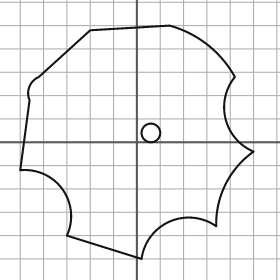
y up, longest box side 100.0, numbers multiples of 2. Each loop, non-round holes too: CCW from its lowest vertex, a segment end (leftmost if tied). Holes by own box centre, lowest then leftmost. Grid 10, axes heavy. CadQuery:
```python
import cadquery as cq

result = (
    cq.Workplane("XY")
    .moveTo(2.0, -50.0)
    .threePointArc((14.0, -34.0), (34.0, -36.0))
    .threePointArc((38.0, -18.0), (50.0, -4.0))
    .threePointArc((38.0, 10.0), (42.0, 28.0))
    .threePointArc((30.0, 42.0), (14.0, 50.0))
    .lineTo(-20.0, 48.0)
    .lineTo(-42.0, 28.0)
    .threePointArc((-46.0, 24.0), (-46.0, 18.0))
    .lineTo(-50.0, -12.0)
    .threePointArc((-32.0, -20.0), (-30.0, -40.0))
    .close()
    .moveTo(6.0, 4.0)
    .circle(4.0)
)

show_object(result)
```